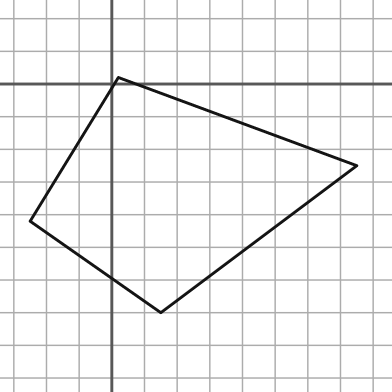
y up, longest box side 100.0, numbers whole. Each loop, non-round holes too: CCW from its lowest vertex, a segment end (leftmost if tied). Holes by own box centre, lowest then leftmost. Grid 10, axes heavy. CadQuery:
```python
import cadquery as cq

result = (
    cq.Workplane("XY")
    .moveTo(15.0, -70.0)
    .lineTo(75.0, -25.0)
    .lineTo(2.0, 2.0)
    .lineTo(-25.0, -42.0)
    .close()
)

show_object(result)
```